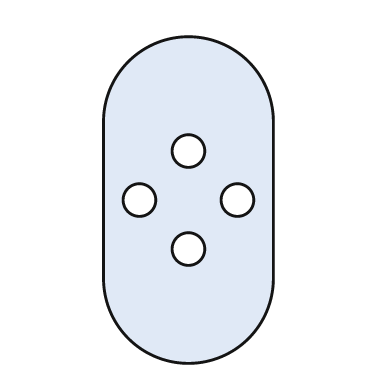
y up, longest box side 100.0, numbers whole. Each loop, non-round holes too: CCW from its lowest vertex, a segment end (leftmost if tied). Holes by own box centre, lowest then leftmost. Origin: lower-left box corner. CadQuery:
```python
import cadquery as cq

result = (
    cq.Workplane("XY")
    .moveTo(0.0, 26.0)
    .threePointArc((26.0, 0.0), (52.0, 26.0))
    .lineTo(52.0, 74.0)
    .threePointArc((26.0, 100.0), (0.0, 74.0))
    .close()
    .moveTo(26.0, 35.0)
    .circle(5.0)
    .moveTo(11.0, 50.0)
    .circle(5.0)
    .moveTo(41.0, 50.0)
    .circle(5.0)
    .moveTo(26.0, 65.0)
    .circle(5.0)
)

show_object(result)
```